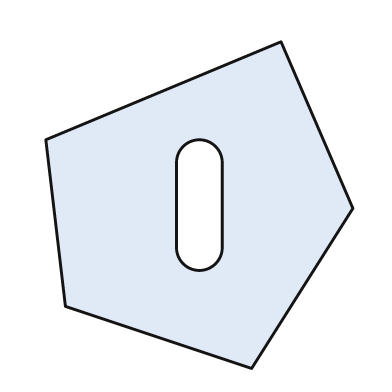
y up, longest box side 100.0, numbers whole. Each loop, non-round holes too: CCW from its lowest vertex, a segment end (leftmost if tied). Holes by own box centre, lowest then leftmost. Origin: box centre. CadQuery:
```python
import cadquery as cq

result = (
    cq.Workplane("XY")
    .moveTo(16.0, -50.0)
    .lineTo(47.0, -1.0)
    .lineTo(25.0, 50.0)
    .lineTo(-47.0, 20.0)
    .lineTo(-41.0, -31.0)
    .close()
    .moveTo(-7.0, -13.0)
    .threePointArc((0.0, -20.0), (7.0, -13.0))
    .lineTo(7.0, 13.0)
    .threePointArc((0.0, 20.0), (-7.0, 13.0))
    .close()
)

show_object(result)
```